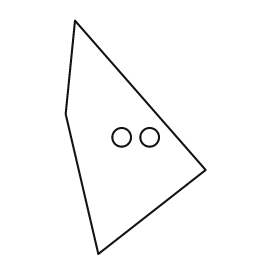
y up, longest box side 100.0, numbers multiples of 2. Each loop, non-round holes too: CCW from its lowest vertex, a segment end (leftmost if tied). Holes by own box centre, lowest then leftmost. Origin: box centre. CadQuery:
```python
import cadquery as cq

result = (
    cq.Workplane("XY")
    .moveTo(-16.0, -50.0)
    .lineTo(30.0, -14.0)
    .lineTo(-26.0, 50.0)
    .lineTo(-30.0, 10.0)
    .close()
    .moveTo(-6.0, 0.0)
    .circle(4.0)
    .moveTo(6.0, 0.0)
    .circle(4.0)
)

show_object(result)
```